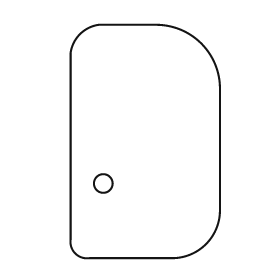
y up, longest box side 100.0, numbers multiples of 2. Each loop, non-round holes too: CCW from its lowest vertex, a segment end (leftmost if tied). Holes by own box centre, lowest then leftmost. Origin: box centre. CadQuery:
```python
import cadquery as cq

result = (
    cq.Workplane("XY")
    .moveTo(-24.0, -50.0)
    .lineTo(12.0, -50.0)
    .threePointArc((26.0, -44.0), (32.0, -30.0))
    .lineTo(32.0, 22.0)
    .threePointArc((24.0, 42.0), (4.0, 50.0))
    .lineTo(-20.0, 50.0)
    .threePointArc((-28.0, 46.0), (-32.0, 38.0))
    .lineTo(-32.0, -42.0)
    .threePointArc((-30.0, -48.0), (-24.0, -50.0))
    .close()
    .moveTo(-18.0, -18.0)
    .circle(4.0)
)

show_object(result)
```